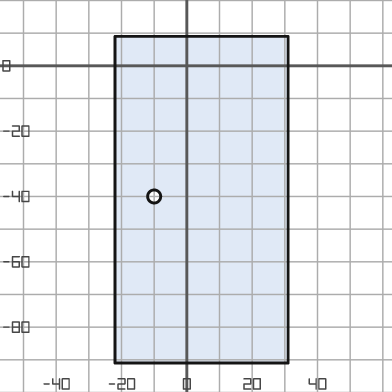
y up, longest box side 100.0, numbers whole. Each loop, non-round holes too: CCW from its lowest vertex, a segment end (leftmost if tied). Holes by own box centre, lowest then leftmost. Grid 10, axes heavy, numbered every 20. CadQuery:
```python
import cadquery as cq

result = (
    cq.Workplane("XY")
    .moveTo(-22.0, -91.0)
    .lineTo(31.0, -91.0)
    .lineTo(31.0, 9.0)
    .lineTo(-22.0, 9.0)
    .close()
    .moveTo(-10.0, -40.0)
    .circle(2.0)
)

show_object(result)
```